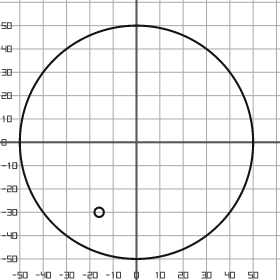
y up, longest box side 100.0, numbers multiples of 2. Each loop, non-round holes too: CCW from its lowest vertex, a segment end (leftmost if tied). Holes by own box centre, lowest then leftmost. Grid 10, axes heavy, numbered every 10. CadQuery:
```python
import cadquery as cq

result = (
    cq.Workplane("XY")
    .moveTo(0.0, 0.0)
    .circle(50.0)
    .moveTo(-16.0, -30.0)
    .circle(2.0)
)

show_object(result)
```